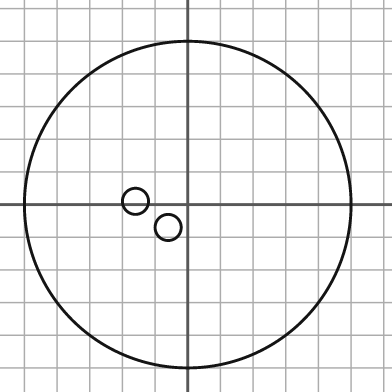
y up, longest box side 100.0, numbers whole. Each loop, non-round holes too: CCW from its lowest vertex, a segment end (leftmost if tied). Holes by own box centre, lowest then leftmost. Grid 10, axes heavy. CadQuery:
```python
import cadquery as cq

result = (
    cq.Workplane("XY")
    .moveTo(0.0, 0.0)
    .circle(50.0)
    .moveTo(-6.0, -7.0)
    .circle(4.0)
    .moveTo(-16.0, 1.0)
    .circle(4.0)
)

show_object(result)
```